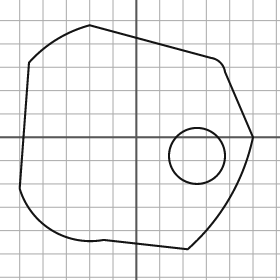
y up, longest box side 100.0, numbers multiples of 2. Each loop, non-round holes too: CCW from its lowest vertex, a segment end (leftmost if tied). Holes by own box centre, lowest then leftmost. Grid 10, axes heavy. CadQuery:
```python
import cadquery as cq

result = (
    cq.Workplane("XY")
    .moveTo(22.0, -48.0)
    .threePointArc((40.0, -26.0), (50.0, 0.0))
    .lineTo(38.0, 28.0)
    .threePointArc((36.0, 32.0), (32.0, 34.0))
    .lineTo(-20.0, 48.0)
    .threePointArc((-34.0, 42.0), (-46.0, 32.0))
    .lineTo(-50.0, -22.0)
    .threePointArc((-36.0, -40.0), (-14.0, -44.0))
    .close()
    .moveTo(26.0, -8.0)
    .circle(12.0)
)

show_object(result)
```